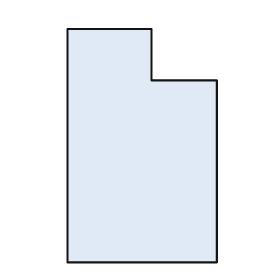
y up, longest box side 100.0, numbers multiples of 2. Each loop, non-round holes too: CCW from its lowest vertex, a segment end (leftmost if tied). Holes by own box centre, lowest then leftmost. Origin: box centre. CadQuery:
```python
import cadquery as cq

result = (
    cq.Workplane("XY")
    .moveTo(-32.0, -50.0)
    .lineTo(32.0, -50.0)
    .lineTo(32.0, 28.0)
    .lineTo(4.0, 28.0)
    .lineTo(4.0, 50.0)
    .lineTo(-32.0, 50.0)
    .close()
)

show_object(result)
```